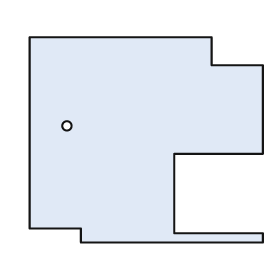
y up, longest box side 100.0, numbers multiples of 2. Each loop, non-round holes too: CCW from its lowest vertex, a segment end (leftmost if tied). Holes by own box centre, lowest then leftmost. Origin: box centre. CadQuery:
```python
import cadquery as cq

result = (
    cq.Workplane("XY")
    .moveTo(-28.0, -44.0)
    .lineTo(50.0, -44.0)
    .lineTo(50.0, -40.0)
    .lineTo(12.0, -40.0)
    .lineTo(12.0, -6.0)
    .lineTo(50.0, -6.0)
    .lineTo(50.0, 32.0)
    .lineTo(28.0, 32.0)
    .lineTo(28.0, 44.0)
    .lineTo(-50.0, 44.0)
    .lineTo(-50.0, -38.0)
    .lineTo(-28.0, -38.0)
    .close()
    .moveTo(-34.0, 6.0)
    .circle(2.0)
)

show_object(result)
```